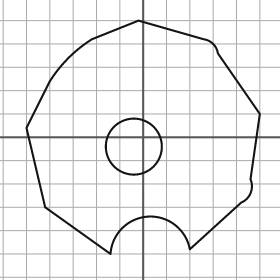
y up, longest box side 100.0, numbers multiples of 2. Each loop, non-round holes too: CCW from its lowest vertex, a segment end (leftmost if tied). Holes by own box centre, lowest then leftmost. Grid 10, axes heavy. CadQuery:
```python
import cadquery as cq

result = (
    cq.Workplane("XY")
    .moveTo(-14.0, -50.0)
    .threePointArc((2.0, -34.0), (20.0, -48.0))
    .lineTo(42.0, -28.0)
    .threePointArc((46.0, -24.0), (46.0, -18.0))
    .lineTo(50.0, 10.0)
    .lineTo(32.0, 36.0)
    .threePointArc((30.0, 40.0), (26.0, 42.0))
    .lineTo(-2.0, 50.0)
    .lineTo(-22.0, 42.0)
    .threePointArc((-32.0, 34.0), (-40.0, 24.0))
    .lineTo(-50.0, 4.0)
    .lineTo(-42.0, -30.0)
    .close()
    .moveTo(-4.0, -4.0)
    .circle(12.0)
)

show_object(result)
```